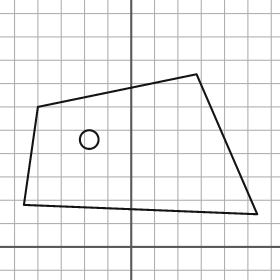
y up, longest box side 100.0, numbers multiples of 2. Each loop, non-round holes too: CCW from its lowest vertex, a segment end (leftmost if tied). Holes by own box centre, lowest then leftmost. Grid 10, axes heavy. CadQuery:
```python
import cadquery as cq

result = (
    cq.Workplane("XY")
    .moveTo(54.0, 14.0)
    .lineTo(28.0, 74.0)
    .lineTo(-40.0, 60.0)
    .lineTo(-46.0, 18.0)
    .close()
    .moveTo(-18.0, 46.0)
    .circle(4.0)
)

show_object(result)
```